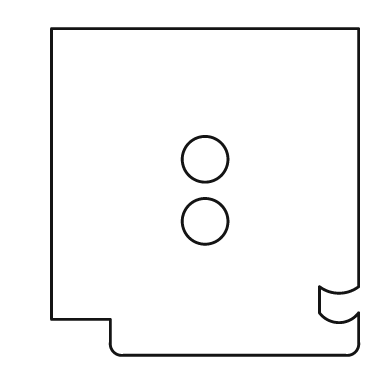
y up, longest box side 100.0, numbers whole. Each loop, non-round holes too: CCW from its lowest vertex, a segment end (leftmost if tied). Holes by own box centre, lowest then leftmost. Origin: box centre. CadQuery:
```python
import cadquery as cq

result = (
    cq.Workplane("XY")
    .moveTo(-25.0, -50.0)
    .lineTo(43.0, -50.0)
    .threePointArc((46.0, -49.0), (47.0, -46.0))
    .lineTo(47.0, -37.0)
    .threePointArc((41.0, -40.0), (35.0, -37.0))
    .lineTo(35.0, -29.0)
    .threePointArc((41.0, -31.0), (47.0, -29.0))
    .lineTo(47.0, 50.0)
    .lineTo(-47.0, 50.0)
    .lineTo(-47.0, -39.0)
    .lineTo(-29.0, -39.0)
    .lineTo(-29.0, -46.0)
    .threePointArc((-28.0, -49.0), (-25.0, -50.0))
    .close()
    .moveTo(0.0, -9.0)
    .circle(7.0)
    .moveTo(0.0, 10.0)
    .circle(7.0)
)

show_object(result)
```